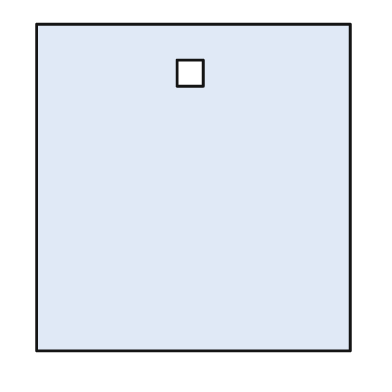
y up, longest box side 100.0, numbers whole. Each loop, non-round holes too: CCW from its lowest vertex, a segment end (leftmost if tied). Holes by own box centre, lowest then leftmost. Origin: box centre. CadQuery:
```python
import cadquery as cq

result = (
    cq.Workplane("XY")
    .moveTo(-48.0, -50.0)
    .lineTo(48.0, -50.0)
    .lineTo(48.0, 50.0)
    .lineTo(-48.0, 50.0)
    .close()
    .moveTo(-5.0, 31.0)
    .lineTo(3.0, 31.0)
    .lineTo(3.0, 39.0)
    .lineTo(-5.0, 39.0)
    .close()
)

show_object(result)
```